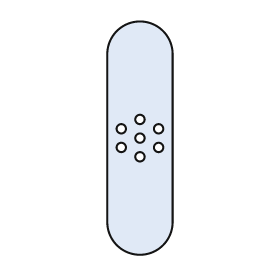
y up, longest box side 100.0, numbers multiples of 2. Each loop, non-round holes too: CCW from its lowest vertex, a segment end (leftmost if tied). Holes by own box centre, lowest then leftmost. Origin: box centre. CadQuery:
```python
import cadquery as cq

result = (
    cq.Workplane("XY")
    .moveTo(-14.0, -36.0)
    .threePointArc((0.0, -50.0), (14.0, -36.0))
    .lineTo(14.0, 36.0)
    .threePointArc((0.0, 50.0), (-14.0, 36.0))
    .close()
    .moveTo(0.0, -8.0)
    .circle(2.0)
    .moveTo(-8.0, -4.0)
    .circle(2.0)
    .moveTo(8.0, -4.0)
    .circle(2.0)
    .moveTo(0.0, 0.0)
    .circle(2.0)
    .moveTo(-8.0, 4.0)
    .circle(2.0)
    .moveTo(8.0, 4.0)
    .circle(2.0)
    .moveTo(0.0, 8.0)
    .circle(2.0)
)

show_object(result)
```